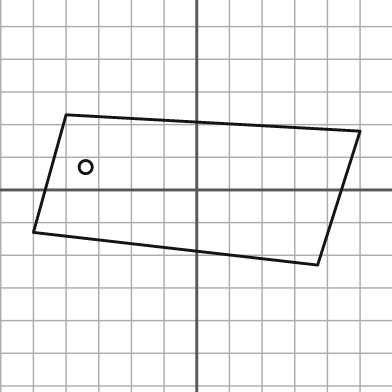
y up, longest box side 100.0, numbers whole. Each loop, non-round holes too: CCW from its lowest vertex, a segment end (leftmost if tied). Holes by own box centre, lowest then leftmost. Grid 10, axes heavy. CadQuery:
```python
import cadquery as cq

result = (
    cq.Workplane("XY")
    .moveTo(37.0, -23.0)
    .lineTo(50.0, 18.0)
    .lineTo(-40.0, 23.0)
    .lineTo(-50.0, -13.0)
    .close()
    .moveTo(-34.0, 7.0)
    .circle(2.0)
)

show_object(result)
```